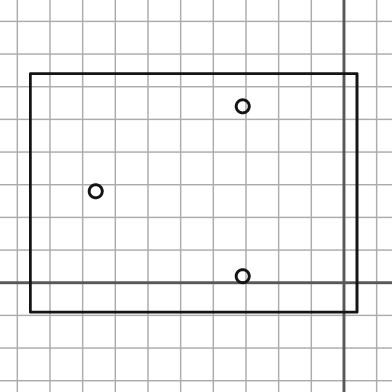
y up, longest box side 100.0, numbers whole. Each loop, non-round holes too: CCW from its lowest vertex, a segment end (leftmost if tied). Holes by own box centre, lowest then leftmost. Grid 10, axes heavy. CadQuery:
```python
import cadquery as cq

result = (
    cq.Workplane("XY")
    .moveTo(-96.0, -9.0)
    .lineTo(4.0, -9.0)
    .lineTo(4.0, 64.0)
    .lineTo(-96.0, 64.0)
    .close()
    .moveTo(-31.0, 2.0)
    .circle(2.0)
    .moveTo(-76.0, 28.0)
    .circle(2.0)
    .moveTo(-31.0, 54.0)
    .circle(2.0)
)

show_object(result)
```